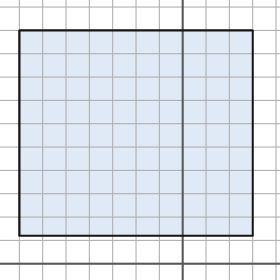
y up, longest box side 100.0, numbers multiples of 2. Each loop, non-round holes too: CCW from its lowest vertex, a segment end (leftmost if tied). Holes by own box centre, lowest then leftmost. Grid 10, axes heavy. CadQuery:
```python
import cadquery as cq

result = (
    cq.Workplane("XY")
    .moveTo(-70.0, 12.0)
    .lineTo(30.0, 12.0)
    .lineTo(30.0, 100.0)
    .lineTo(-70.0, 100.0)
    .close()
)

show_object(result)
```